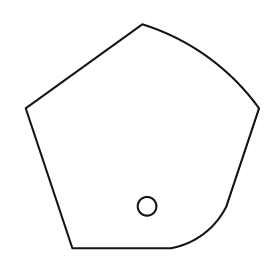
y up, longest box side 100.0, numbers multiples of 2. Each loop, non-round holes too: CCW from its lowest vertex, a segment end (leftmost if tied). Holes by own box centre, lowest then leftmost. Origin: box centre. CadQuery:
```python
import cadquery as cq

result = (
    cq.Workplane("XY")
    .moveTo(-30.0, -48.0)
    .lineTo(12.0, -48.0)
    .threePointArc((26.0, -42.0), (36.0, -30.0))
    .lineTo(50.0, 12.0)
    .threePointArc((28.0, 34.0), (0.0, 48.0))
    .lineTo(-50.0, 12.0)
    .close()
    .moveTo(2.0, -30.0)
    .circle(4.0)
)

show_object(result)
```